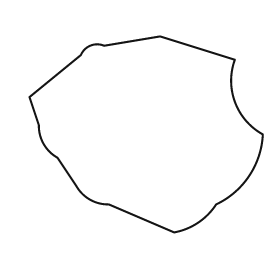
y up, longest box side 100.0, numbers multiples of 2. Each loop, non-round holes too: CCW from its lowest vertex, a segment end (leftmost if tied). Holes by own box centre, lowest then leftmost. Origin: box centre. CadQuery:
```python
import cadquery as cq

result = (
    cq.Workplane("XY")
    .moveTo(12.0, -42.0)
    .threePointArc((22.0, -38.0), (30.0, -30.0))
    .threePointArc((44.0, -18.0), (50.0, 0.0))
    .threePointArc((38.0, 14.0), (38.0, 32.0))
    .lineTo(6.0, 42.0)
    .lineTo(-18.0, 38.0)
    .threePointArc((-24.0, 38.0), (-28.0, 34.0))
    .lineTo(-50.0, 16.0)
    .lineTo(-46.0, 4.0)
    .threePointArc((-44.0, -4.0), (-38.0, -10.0))
    .lineTo(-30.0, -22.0)
    .threePointArc((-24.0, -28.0), (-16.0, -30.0))
    .close()
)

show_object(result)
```